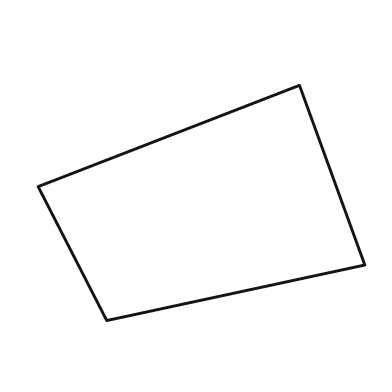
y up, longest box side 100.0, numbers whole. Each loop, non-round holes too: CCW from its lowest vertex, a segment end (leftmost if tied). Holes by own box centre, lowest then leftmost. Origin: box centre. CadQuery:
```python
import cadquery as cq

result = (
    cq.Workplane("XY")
    .moveTo(-29.0, -36.0)
    .lineTo(50.0, -19.0)
    .lineTo(30.0, 36.0)
    .lineTo(-50.0, 5.0)
    .close()
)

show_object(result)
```